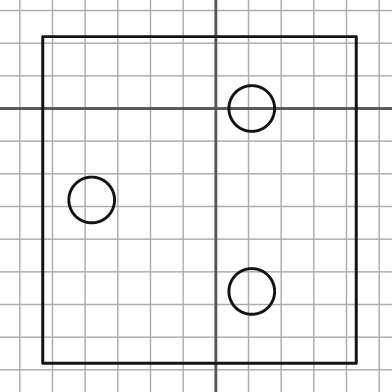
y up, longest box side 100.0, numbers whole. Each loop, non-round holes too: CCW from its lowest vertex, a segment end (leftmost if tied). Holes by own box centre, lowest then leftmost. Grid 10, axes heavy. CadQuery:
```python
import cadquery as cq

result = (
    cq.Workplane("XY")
    .moveTo(-53.0, -78.0)
    .lineTo(43.0, -78.0)
    .lineTo(43.0, 22.0)
    .lineTo(-53.0, 22.0)
    .close()
    .moveTo(11.0, -56.0)
    .circle(7.0)
    .moveTo(-38.0, -28.0)
    .circle(7.0)
    .moveTo(11.0, 0.0)
    .circle(7.0)
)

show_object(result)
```